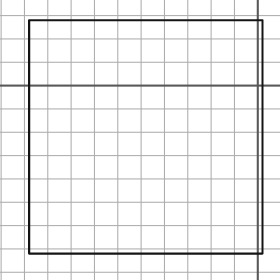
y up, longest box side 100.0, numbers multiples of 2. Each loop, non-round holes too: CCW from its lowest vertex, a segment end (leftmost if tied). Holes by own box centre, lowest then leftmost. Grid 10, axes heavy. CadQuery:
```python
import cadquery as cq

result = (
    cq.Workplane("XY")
    .moveTo(-98.0, -72.0)
    .lineTo(2.0, -72.0)
    .lineTo(2.0, 28.0)
    .lineTo(-98.0, 28.0)
    .close()
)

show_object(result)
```